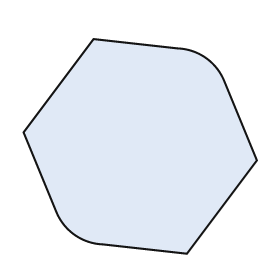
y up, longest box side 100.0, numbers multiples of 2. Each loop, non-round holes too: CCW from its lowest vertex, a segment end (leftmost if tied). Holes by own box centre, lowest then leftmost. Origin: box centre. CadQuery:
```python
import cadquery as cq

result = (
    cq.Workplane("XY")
    .moveTo(20.0, -46.0)
    .lineTo(50.0, -6.0)
    .lineTo(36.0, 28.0)
    .threePointArc((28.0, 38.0), (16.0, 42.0))
    .lineTo(-20.0, 46.0)
    .lineTo(-50.0, 6.0)
    .lineTo(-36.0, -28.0)
    .threePointArc((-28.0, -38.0), (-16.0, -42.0))
    .close()
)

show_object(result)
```